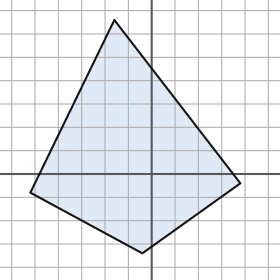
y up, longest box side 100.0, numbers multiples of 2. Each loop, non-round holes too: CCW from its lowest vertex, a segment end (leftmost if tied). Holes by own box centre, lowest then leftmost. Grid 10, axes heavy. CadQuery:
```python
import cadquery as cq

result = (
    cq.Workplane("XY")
    .moveTo(-4.0, -34.0)
    .lineTo(38.0, -4.0)
    .lineTo(-16.0, 66.0)
    .lineTo(-52.0, -8.0)
    .close()
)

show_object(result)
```